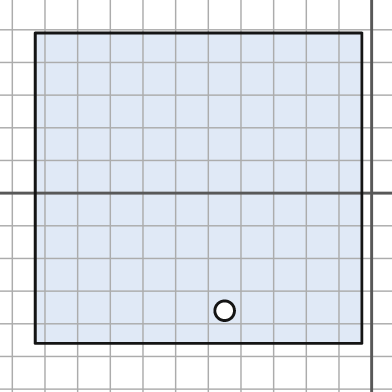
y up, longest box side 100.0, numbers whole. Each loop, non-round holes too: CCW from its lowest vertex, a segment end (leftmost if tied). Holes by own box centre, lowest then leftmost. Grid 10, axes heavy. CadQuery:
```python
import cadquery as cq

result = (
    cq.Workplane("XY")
    .moveTo(-103.0, -46.0)
    .lineTo(-3.0, -46.0)
    .lineTo(-3.0, 49.0)
    .lineTo(-103.0, 49.0)
    .close()
    .moveTo(-45.0, -36.0)
    .circle(3.0)
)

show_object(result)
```